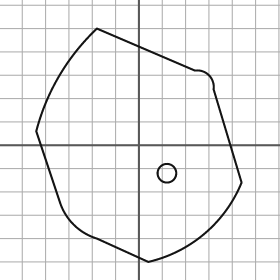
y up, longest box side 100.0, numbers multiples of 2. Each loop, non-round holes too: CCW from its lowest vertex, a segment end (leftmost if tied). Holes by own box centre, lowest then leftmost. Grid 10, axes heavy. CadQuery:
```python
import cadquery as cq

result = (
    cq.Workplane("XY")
    .moveTo(4.0, -50.0)
    .threePointArc((28.0, -38.0), (44.0, -16.0))
    .lineTo(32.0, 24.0)
    .threePointArc((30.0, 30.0), (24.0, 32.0))
    .lineTo(-18.0, 50.0)
    .threePointArc((-34.0, 30.0), (-44.0, 6.0))
    .lineTo(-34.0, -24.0)
    .threePointArc((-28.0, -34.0), (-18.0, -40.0))
    .close()
    .moveTo(12.0, -12.0)
    .circle(4.0)
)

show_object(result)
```